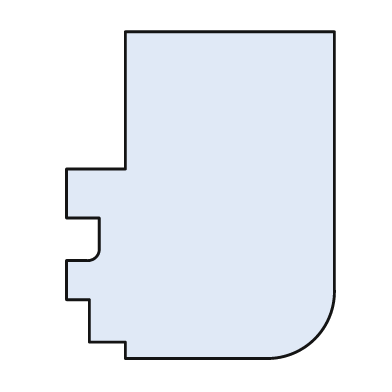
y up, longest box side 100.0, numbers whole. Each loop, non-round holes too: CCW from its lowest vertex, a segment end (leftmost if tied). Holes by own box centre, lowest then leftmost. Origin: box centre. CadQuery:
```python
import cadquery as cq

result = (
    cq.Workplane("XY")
    .moveTo(-23.0, -50.0)
    .lineTo(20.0, -50.0)
    .threePointArc((35.0, -44.0), (41.0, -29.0))
    .lineTo(41.0, 50.0)
    .lineTo(-23.0, 50.0)
    .lineTo(-23.0, 8.0)
    .lineTo(-41.0, 8.0)
    .lineTo(-41.0, -7.0)
    .lineTo(-31.0, -7.0)
    .lineTo(-31.0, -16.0)
    .threePointArc((-32.0, -19.0), (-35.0, -20.0))
    .lineTo(-41.0, -20.0)
    .lineTo(-41.0, -32.0)
    .lineTo(-34.0, -32.0)
    .lineTo(-34.0, -45.0)
    .lineTo(-23.0, -45.0)
    .close()
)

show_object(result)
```